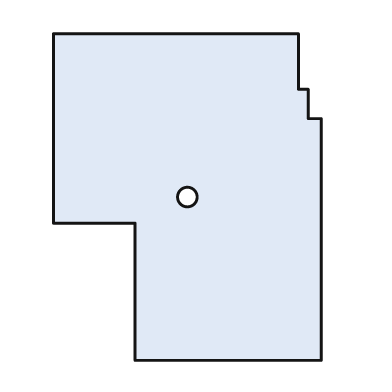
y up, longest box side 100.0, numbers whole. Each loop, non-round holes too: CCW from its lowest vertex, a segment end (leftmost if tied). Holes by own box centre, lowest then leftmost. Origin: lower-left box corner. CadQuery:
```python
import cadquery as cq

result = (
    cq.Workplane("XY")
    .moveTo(25.0, 0.0)
    .lineTo(82.0, 0.0)
    .lineTo(82.0, 74.0)
    .lineTo(78.0, 74.0)
    .lineTo(78.0, 83.0)
    .lineTo(75.0, 83.0)
    .lineTo(75.0, 100.0)
    .lineTo(0.0, 100.0)
    .lineTo(0.0, 42.0)
    .lineTo(25.0, 42.0)
    .close()
    .moveTo(41.0, 50.0)
    .circle(3.0)
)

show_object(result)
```